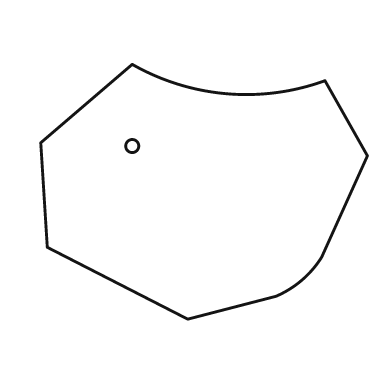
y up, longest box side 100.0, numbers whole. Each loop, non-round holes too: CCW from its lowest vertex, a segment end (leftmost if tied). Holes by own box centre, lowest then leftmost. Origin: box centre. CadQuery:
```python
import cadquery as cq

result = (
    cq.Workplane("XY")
    .moveTo(-5.0, -39.0)
    .lineTo(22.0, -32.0)
    .threePointArc((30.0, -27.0), (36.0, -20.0))
    .lineTo(50.0, 11.0)
    .lineTo(37.0, 34.0)
    .threePointArc((7.0, 30.0), (-22.0, 39.0))
    .lineTo(-50.0, 15.0)
    .lineTo(-48.0, -17.0)
    .close()
    .moveTo(-22.0, 14.0)
    .circle(2.0)
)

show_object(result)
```